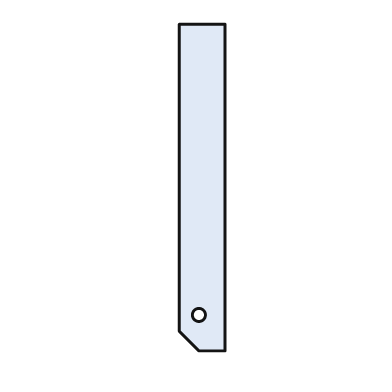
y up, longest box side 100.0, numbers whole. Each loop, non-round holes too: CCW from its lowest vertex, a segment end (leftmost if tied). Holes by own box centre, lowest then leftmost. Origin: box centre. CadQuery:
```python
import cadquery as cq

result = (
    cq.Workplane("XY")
    .moveTo(-1.0, -50.0)
    .lineTo(7.0, -50.0)
    .lineTo(7.0, 50.0)
    .lineTo(-7.0, 50.0)
    .lineTo(-7.0, -44.0)
    .close()
    .moveTo(-1.0, -39.0)
    .circle(2.0)
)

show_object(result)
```